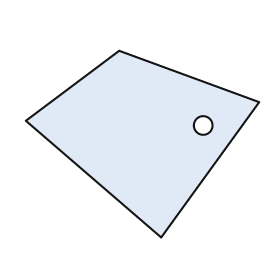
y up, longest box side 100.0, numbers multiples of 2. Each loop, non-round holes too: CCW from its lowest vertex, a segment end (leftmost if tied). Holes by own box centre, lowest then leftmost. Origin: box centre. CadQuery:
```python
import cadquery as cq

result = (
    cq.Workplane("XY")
    .moveTo(8.0, -40.0)
    .lineTo(50.0, 18.0)
    .lineTo(-10.0, 40.0)
    .lineTo(-50.0, 10.0)
    .close()
    .moveTo(26.0, 8.0)
    .circle(4.0)
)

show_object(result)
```